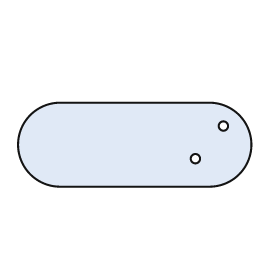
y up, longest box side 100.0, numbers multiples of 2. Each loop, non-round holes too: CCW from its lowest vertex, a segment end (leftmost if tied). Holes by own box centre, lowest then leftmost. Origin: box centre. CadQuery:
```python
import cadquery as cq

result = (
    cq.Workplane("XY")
    .moveTo(-32.0, -18.0)
    .lineTo(32.0, -18.0)
    .threePointArc((50.0, 0.0), (32.0, 18.0))
    .lineTo(-32.0, 18.0)
    .threePointArc((-50.0, 0.0), (-32.0, -18.0))
    .close()
    .moveTo(26.0, -6.0)
    .circle(2.0)
    .moveTo(38.0, 8.0)
    .circle(2.0)
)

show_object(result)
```